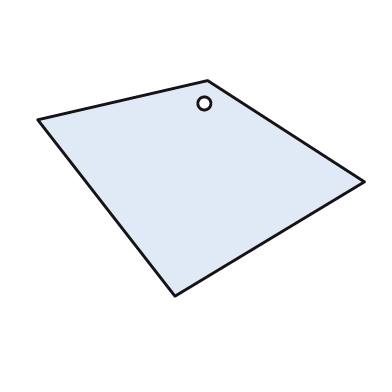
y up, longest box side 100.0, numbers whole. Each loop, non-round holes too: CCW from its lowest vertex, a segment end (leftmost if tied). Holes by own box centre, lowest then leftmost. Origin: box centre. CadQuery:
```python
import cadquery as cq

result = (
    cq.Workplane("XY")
    .moveTo(-8.0, -33.0)
    .lineTo(50.0, 2.0)
    .lineTo(2.0, 33.0)
    .lineTo(-50.0, 21.0)
    .close()
    .moveTo(1.0, 26.0)
    .circle(2.0)
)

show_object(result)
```